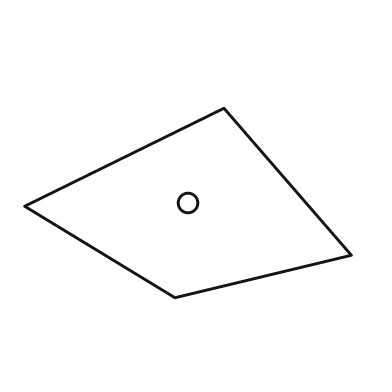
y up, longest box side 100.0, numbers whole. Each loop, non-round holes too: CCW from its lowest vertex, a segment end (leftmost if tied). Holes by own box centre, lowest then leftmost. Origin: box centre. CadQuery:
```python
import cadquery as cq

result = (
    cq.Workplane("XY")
    .moveTo(-4.0, -29.0)
    .lineTo(50.0, -16.0)
    .lineTo(11.0, 29.0)
    .lineTo(-50.0, -1.0)
    .close()
    .moveTo(0.0, 0.0)
    .circle(3.0)
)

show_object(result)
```